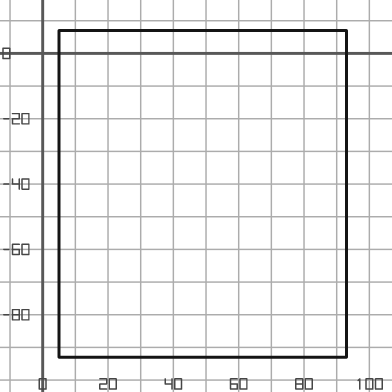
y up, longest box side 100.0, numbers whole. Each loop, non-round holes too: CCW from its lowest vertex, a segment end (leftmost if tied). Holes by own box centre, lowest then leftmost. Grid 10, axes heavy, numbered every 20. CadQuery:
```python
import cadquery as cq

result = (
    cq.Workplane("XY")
    .moveTo(5.0, -93.0)
    .lineTo(93.0, -93.0)
    .lineTo(93.0, 7.0)
    .lineTo(5.0, 7.0)
    .close()
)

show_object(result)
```